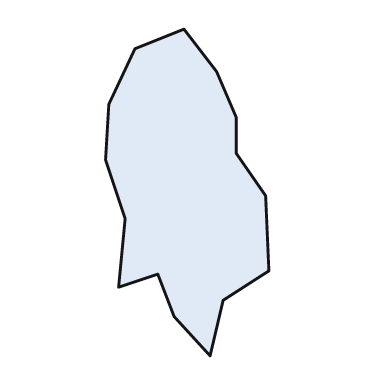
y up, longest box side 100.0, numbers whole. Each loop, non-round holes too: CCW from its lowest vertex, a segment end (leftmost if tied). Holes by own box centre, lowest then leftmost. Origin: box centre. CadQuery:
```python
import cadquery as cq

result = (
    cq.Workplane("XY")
    .moveTo(7.0, -50.0)
    .lineTo(11.0, -33.0)
    .lineTo(25.0, -24.0)
    .lineTo(24.0, -1.0)
    .lineTo(15.0, 12.0)
    .lineTo(15.0, 23.0)
    .lineTo(9.0, 37.0)
    .lineTo(-1.0, 50.0)
    .lineTo(-16.0, 44.0)
    .lineTo(-24.0, 27.0)
    .lineTo(-25.0, 10.0)
    .lineTo(-19.0, -8.0)
    .lineTo(-21.0, -29.0)
    .lineTo(-9.0, -25.0)
    .lineTo(-4.0, -38.0)
    .close()
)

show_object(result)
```